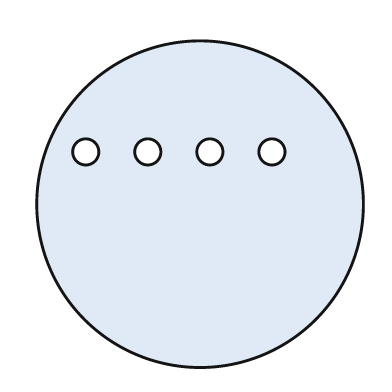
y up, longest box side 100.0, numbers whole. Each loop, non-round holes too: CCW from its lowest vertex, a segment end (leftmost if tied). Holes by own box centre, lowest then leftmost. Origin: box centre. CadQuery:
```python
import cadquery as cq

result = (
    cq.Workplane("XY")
    .moveTo(0.0, 0.0)
    .circle(50.0)
    .moveTo(-35.0, 16.0)
    .circle(4.0)
    .moveTo(-16.0, 16.0)
    .circle(4.0)
    .moveTo(3.0, 16.0)
    .circle(4.0)
    .moveTo(22.0, 16.0)
    .circle(4.0)
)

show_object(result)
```